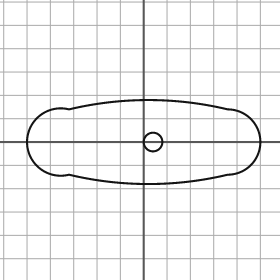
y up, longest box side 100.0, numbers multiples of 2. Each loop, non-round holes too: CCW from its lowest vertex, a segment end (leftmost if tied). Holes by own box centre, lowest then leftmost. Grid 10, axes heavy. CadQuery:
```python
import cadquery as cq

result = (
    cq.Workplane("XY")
    .moveTo(-32.0, -14.0)
    .threePointArc((2.0, -18.0), (36.0, -14.0))
    .threePointArc((50.0, 0.0), (36.0, 14.0))
    .threePointArc((2.0, 18.0), (-32.0, 14.0))
    .threePointArc((-50.0, 0.0), (-32.0, -14.0))
    .close()
    .moveTo(4.0, 0.0)
    .circle(4.0)
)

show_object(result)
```